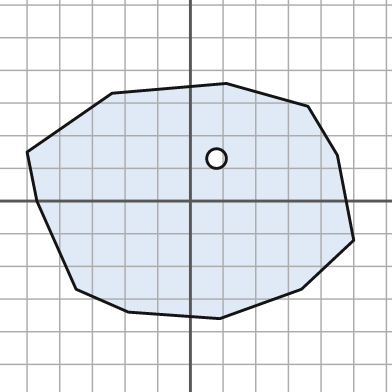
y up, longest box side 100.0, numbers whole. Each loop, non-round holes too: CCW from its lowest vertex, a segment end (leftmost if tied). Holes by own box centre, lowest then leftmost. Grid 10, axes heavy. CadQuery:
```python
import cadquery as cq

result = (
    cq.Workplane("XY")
    .moveTo(9.0, -36.0)
    .lineTo(34.0, -27.0)
    .lineTo(50.0, -12.0)
    .lineTo(45.0, 14.0)
    .lineTo(36.0, 29.0)
    .lineTo(11.0, 36.0)
    .lineTo(-24.0, 33.0)
    .lineTo(-50.0, 15.0)
    .lineTo(-47.0, 0.0)
    .lineTo(-35.0, -27.0)
    .lineTo(-19.0, -34.0)
    .close()
    .moveTo(8.0, 13.0)
    .circle(3.0)
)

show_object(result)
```